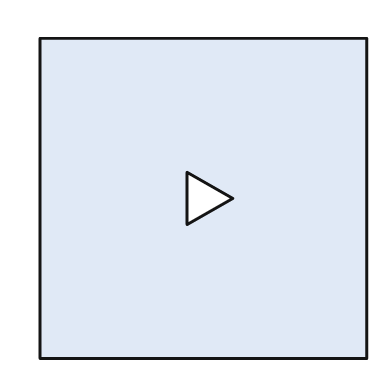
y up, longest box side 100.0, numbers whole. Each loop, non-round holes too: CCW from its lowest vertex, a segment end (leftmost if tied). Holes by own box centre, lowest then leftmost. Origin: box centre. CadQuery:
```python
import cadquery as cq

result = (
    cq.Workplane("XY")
    .moveTo(-50.0, -49.0)
    .lineTo(50.0, -49.0)
    .lineTo(50.0, 49.0)
    .lineTo(-50.0, 49.0)
    .close()
    .moveTo(-5.0, -8.0)
    .lineTo(9.0, 0.0)
    .lineTo(-5.0, 8.0)
    .close()
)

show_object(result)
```